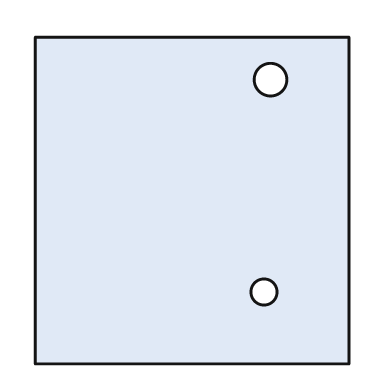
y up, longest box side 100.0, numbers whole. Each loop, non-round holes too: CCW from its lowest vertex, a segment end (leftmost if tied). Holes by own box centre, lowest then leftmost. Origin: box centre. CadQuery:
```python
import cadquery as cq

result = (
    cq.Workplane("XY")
    .moveTo(-48.0, -50.0)
    .lineTo(48.0, -50.0)
    .lineTo(48.0, 50.0)
    .lineTo(-48.0, 50.0)
    .close()
    .moveTo(22.0, -28.0)
    .circle(4.0)
    .moveTo(24.0, 37.0)
    .circle(5.0)
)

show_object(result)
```